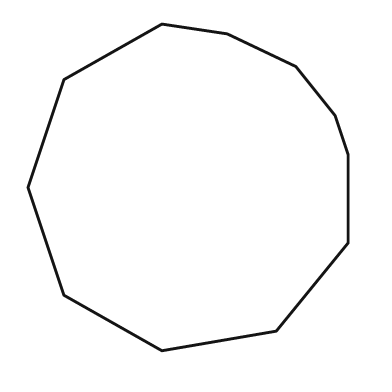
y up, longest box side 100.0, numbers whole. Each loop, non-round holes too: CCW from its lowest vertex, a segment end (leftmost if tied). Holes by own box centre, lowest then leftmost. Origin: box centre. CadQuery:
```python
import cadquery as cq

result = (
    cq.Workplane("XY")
    .moveTo(-8.0, -50.0)
    .lineTo(27.0, -44.0)
    .lineTo(49.0, -17.0)
    .lineTo(49.0, 10.0)
    .lineTo(45.0, 22.0)
    .lineTo(33.0, 37.0)
    .lineTo(12.0, 47.0)
    .lineTo(-8.0, 50.0)
    .lineTo(-38.0, 33.0)
    .lineTo(-49.0, 0.0)
    .lineTo(-38.0, -33.0)
    .close()
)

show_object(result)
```